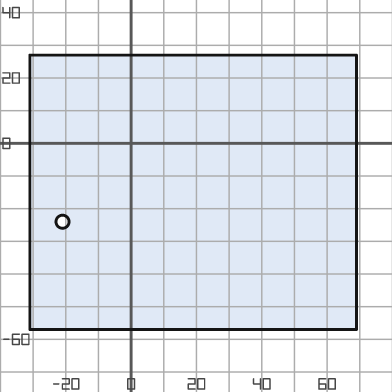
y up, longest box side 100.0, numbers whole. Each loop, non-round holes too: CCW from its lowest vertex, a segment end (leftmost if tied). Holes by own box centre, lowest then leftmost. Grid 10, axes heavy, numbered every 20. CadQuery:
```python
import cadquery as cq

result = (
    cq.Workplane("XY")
    .moveTo(-31.0, -57.0)
    .lineTo(69.0, -57.0)
    .lineTo(69.0, 27.0)
    .lineTo(-31.0, 27.0)
    .close()
    .moveTo(-21.0, -24.0)
    .circle(2.0)
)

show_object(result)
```